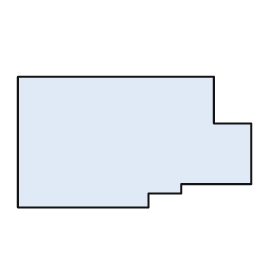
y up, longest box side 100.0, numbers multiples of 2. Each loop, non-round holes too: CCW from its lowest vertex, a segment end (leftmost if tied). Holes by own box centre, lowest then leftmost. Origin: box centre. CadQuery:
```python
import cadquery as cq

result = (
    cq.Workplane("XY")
    .moveTo(-50.0, -28.0)
    .lineTo(6.0, -28.0)
    .lineTo(6.0, -22.0)
    .lineTo(20.0, -22.0)
    .lineTo(20.0, -18.0)
    .lineTo(50.0, -18.0)
    .lineTo(50.0, 8.0)
    .lineTo(34.0, 8.0)
    .lineTo(34.0, 28.0)
    .lineTo(-50.0, 28.0)
    .close()
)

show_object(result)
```